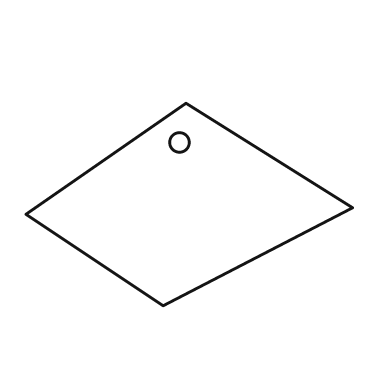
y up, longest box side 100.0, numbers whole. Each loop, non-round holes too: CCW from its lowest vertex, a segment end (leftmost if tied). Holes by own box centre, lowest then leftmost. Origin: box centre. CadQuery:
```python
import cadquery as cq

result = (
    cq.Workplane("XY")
    .moveTo(-8.0, -31.0)
    .lineTo(50.0, -1.0)
    .lineTo(-1.0, 31.0)
    .lineTo(-50.0, -3.0)
    .close()
    .moveTo(-3.0, 19.0)
    .circle(3.0)
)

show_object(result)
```